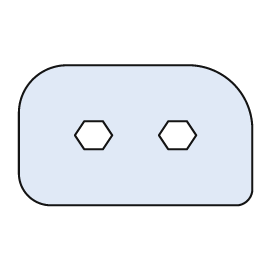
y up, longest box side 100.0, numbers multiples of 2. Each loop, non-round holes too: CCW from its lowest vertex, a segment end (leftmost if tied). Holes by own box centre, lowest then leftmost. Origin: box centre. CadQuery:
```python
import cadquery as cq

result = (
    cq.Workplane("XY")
    .moveTo(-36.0, -30.0)
    .lineTo(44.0, -30.0)
    .threePointArc((48.0, -28.0), (50.0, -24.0))
    .lineTo(50.0, 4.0)
    .threePointArc((42.0, 22.0), (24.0, 30.0))
    .lineTo(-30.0, 30.0)
    .threePointArc((-44.0, 24.0), (-50.0, 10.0))
    .lineTo(-50.0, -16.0)
    .threePointArc((-46.0, -26.0), (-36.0, -30.0))
    .close()
    .moveTo(-22.0, -6.0)
    .lineTo(-14.0, -6.0)
    .lineTo(-10.0, 0.0)
    .lineTo(-14.0, 6.0)
    .lineTo(-22.0, 6.0)
    .lineTo(-26.0, 0.0)
    .close()
    .moveTo(14.0, -6.0)
    .lineTo(22.0, -6.0)
    .lineTo(26.0, 0.0)
    .lineTo(22.0, 6.0)
    .lineTo(14.0, 6.0)
    .lineTo(10.0, 0.0)
    .close()
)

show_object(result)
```